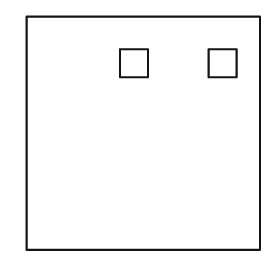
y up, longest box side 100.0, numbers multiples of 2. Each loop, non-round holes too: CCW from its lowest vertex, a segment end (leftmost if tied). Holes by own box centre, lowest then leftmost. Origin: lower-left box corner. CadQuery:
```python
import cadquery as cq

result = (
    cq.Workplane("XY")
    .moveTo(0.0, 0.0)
    .lineTo(100.0, 0.0)
    .lineTo(100.0, 100.0)
    .lineTo(0.0, 100.0)
    .close()
    .moveTo(40.0, 74.0)
    .lineTo(52.0, 74.0)
    .lineTo(52.0, 86.0)
    .lineTo(40.0, 86.0)
    .close()
    .moveTo(78.0, 74.0)
    .lineTo(90.0, 74.0)
    .lineTo(90.0, 86.0)
    .lineTo(78.0, 86.0)
    .close()
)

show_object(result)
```